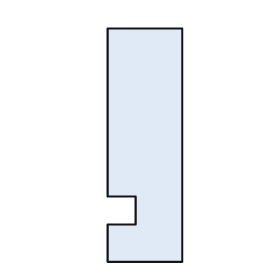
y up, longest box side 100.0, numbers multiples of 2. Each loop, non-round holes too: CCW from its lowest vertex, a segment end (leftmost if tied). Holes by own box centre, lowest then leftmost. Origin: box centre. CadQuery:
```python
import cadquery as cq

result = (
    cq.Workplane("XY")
    .moveTo(-16.0, -50.0)
    .lineTo(16.0, -50.0)
    .lineTo(16.0, 50.0)
    .lineTo(-16.0, 50.0)
    .lineTo(-16.0, -22.0)
    .lineTo(-4.0, -22.0)
    .lineTo(-4.0, -34.0)
    .lineTo(-16.0, -34.0)
    .close()
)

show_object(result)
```